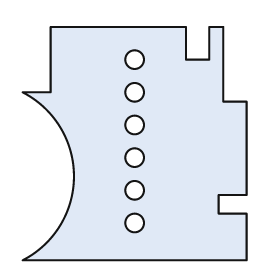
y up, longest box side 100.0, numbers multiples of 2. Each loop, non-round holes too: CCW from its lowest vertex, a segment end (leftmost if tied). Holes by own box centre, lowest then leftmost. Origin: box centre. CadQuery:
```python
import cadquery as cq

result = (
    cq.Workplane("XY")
    .moveTo(-48.0, -50.0)
    .lineTo(48.0, -50.0)
    .lineTo(48.0, -30.0)
    .lineTo(36.0, -30.0)
    .lineTo(36.0, -22.0)
    .lineTo(48.0, -22.0)
    .lineTo(48.0, 18.0)
    .lineTo(38.0, 18.0)
    .lineTo(38.0, 50.0)
    .lineTo(32.0, 50.0)
    .lineTo(32.0, 36.0)
    .lineTo(22.0, 36.0)
    .lineTo(22.0, 50.0)
    .lineTo(-36.0, 50.0)
    .lineTo(-36.0, 22.0)
    .lineTo(-48.0, 22.0)
    .threePointArc((-26.0, -14.0), (-48.0, -50.0))
    .close()
    .moveTo(0.0, -34.0)
    .circle(4.0)
    .moveTo(0.0, -20.0)
    .circle(4.0)
    .moveTo(0.0, -6.0)
    .circle(4.0)
    .moveTo(0.0, 8.0)
    .circle(4.0)
    .moveTo(0.0, 22.0)
    .circle(4.0)
    .moveTo(0.0, 36.0)
    .circle(4.0)
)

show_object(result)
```